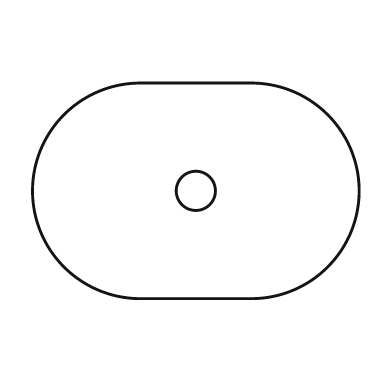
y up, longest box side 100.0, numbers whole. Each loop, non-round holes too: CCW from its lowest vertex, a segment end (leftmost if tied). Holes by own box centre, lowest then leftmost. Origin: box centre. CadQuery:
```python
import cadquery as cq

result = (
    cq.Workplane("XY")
    .moveTo(-17.0, -33.0)
    .lineTo(17.0, -33.0)
    .threePointArc((50.0, 0.0), (17.0, 33.0))
    .lineTo(-17.0, 33.0)
    .threePointArc((-50.0, 0.0), (-17.0, -33.0))
    .close()
    .moveTo(0.0, 0.0)
    .circle(6.0)
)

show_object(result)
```